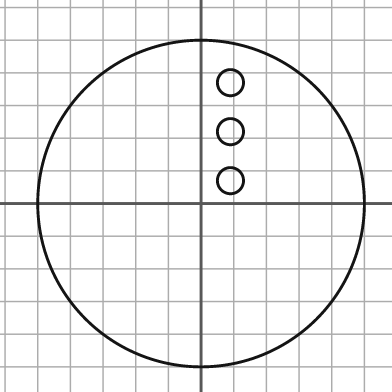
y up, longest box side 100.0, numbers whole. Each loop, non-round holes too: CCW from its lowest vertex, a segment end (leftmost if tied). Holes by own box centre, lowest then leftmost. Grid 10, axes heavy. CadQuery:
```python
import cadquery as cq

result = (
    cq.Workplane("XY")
    .moveTo(0.0, 0.0)
    .circle(50.0)
    .moveTo(9.0, 7.0)
    .circle(4.0)
    .moveTo(9.0, 22.0)
    .circle(4.0)
    .moveTo(9.0, 37.0)
    .circle(4.0)
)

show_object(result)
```